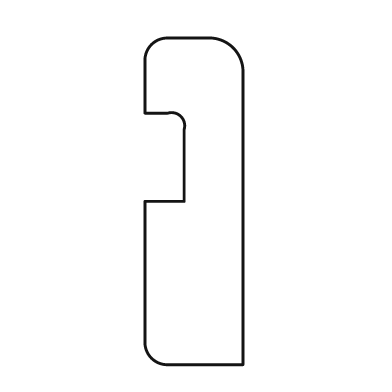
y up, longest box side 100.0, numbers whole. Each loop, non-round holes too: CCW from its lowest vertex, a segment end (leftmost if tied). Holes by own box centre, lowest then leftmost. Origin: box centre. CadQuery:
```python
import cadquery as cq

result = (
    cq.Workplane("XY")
    .moveTo(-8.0, -50.0)
    .lineTo(15.0, -50.0)
    .lineTo(15.0, 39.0)
    .threePointArc((12.0, 47.0), (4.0, 50.0))
    .lineTo(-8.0, 50.0)
    .threePointArc((-13.0, 48.0), (-15.0, 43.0))
    .lineTo(-15.0, 27.0)
    .lineTo(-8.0, 27.0)
    .threePointArc((-4.0, 26.0), (-3.0, 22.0))
    .lineTo(-3.0, 0.0)
    .lineTo(-15.0, 0.0)
    .lineTo(-15.0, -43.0)
    .threePointArc((-13.0, -48.0), (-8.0, -50.0))
    .close()
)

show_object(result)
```